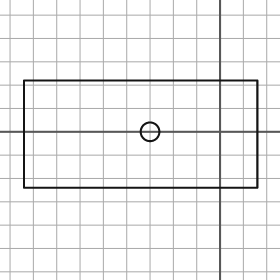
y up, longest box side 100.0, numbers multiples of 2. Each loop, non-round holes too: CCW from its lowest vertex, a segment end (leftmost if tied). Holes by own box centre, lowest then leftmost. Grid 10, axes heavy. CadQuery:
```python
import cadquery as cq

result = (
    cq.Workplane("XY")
    .moveTo(-84.0, -24.0)
    .lineTo(16.0, -24.0)
    .lineTo(16.0, 22.0)
    .lineTo(-84.0, 22.0)
    .close()
    .moveTo(-30.0, 0.0)
    .circle(4.0)
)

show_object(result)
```